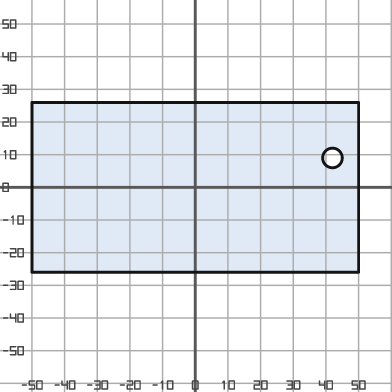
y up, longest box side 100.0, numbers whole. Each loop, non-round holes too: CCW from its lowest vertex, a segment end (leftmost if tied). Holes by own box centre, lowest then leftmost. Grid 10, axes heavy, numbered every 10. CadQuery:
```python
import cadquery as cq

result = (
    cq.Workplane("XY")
    .moveTo(-50.0, -26.0)
    .lineTo(50.0, -26.0)
    .lineTo(50.0, 26.0)
    .lineTo(-50.0, 26.0)
    .close()
    .moveTo(42.0, 9.0)
    .circle(3.0)
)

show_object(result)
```